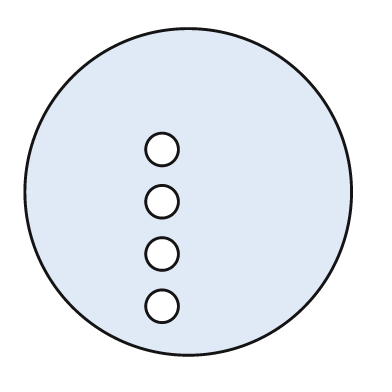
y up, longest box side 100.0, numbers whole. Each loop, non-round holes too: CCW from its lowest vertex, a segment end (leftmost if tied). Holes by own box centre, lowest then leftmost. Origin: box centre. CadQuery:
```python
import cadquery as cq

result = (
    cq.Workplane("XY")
    .moveTo(0.0, 0.0)
    .circle(50.0)
    .moveTo(-8.0, -35.0)
    .circle(5.0)
    .moveTo(-8.0, -19.0)
    .circle(5.0)
    .moveTo(-8.0, -3.0)
    .circle(5.0)
    .moveTo(-8.0, 13.0)
    .circle(5.0)
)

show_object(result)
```